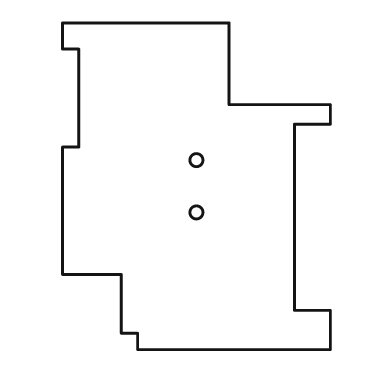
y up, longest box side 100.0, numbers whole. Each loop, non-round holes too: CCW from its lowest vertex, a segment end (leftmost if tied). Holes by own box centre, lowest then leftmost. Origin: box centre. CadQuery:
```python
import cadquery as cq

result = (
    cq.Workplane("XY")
    .moveTo(-18.0, -50.0)
    .lineTo(41.0, -50.0)
    .lineTo(41.0, -38.0)
    .lineTo(30.0, -38.0)
    .lineTo(30.0, 19.0)
    .lineTo(41.0, 19.0)
    .lineTo(41.0, 25.0)
    .lineTo(10.0, 25.0)
    .lineTo(10.0, 50.0)
    .lineTo(-41.0, 50.0)
    .lineTo(-41.0, 42.0)
    .lineTo(-36.0, 42.0)
    .lineTo(-36.0, 12.0)
    .lineTo(-41.0, 12.0)
    .lineTo(-41.0, -27.0)
    .lineTo(-23.0, -27.0)
    .lineTo(-23.0, -45.0)
    .lineTo(-18.0, -45.0)
    .close()
    .moveTo(0.0, -8.0)
    .circle(2.0)
    .moveTo(0.0, 8.0)
    .circle(2.0)
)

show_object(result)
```